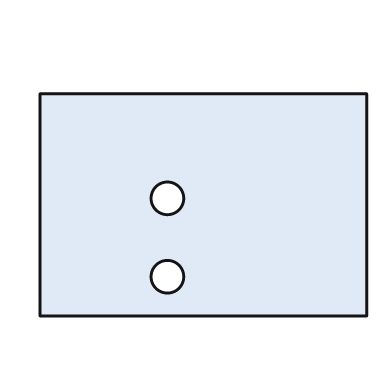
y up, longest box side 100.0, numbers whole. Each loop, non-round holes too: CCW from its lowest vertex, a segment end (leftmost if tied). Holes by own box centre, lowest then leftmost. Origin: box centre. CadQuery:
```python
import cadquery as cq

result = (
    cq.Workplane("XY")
    .moveTo(-50.0, -34.0)
    .lineTo(50.0, -34.0)
    .lineTo(50.0, 34.0)
    .lineTo(-50.0, 34.0)
    .close()
    .moveTo(-11.0, -22.0)
    .circle(5.0)
    .moveTo(-11.0, 2.0)
    .circle(5.0)
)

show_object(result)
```